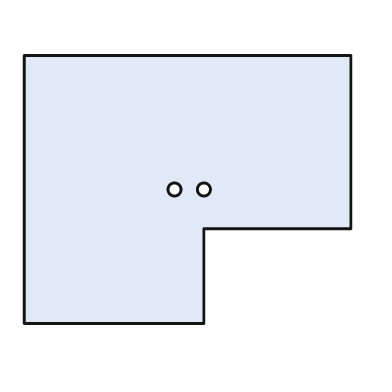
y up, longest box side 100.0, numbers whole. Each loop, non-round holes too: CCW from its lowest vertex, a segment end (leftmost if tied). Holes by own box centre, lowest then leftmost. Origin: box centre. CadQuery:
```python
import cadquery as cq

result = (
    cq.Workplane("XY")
    .moveTo(-50.0, -41.0)
    .lineTo(5.0, -41.0)
    .lineTo(5.0, -12.0)
    .lineTo(50.0, -12.0)
    .lineTo(50.0, 41.0)
    .lineTo(-50.0, 41.0)
    .close()
    .moveTo(-4.0, 0.0)
    .circle(2.0)
    .moveTo(5.0, 0.0)
    .circle(2.0)
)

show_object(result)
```